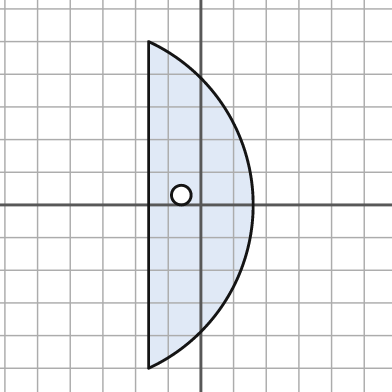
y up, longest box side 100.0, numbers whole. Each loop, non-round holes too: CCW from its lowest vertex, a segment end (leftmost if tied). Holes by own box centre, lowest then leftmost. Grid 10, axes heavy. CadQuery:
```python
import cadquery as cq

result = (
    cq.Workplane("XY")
    .moveTo(-16.0, -50.0)
    .threePointArc((16.0, 0.0), (-16.0, 50.0))
    .close()
    .moveTo(-6.0, 3.0)
    .circle(3.0)
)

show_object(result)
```